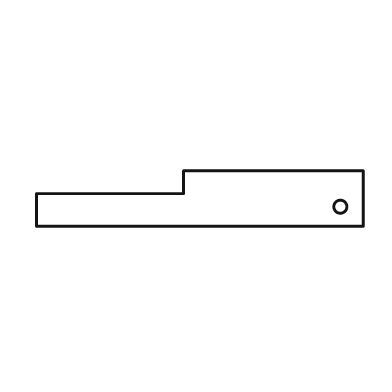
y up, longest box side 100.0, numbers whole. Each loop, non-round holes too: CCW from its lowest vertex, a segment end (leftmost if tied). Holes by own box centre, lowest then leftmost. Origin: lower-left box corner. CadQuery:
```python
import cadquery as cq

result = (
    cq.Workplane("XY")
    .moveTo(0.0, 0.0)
    .lineTo(100.0, 0.0)
    .lineTo(100.0, 17.0)
    .lineTo(45.0, 17.0)
    .lineTo(45.0, 10.0)
    .lineTo(0.0, 10.0)
    .close()
    .moveTo(93.0, 6.0)
    .circle(2.0)
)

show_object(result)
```